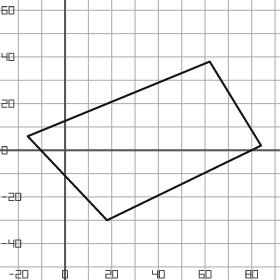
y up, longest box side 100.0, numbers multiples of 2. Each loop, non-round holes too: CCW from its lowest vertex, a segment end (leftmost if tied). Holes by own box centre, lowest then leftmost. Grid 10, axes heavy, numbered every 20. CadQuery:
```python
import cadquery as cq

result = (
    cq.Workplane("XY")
    .moveTo(18.0, -30.0)
    .lineTo(84.0, 2.0)
    .lineTo(62.0, 38.0)
    .lineTo(-16.0, 6.0)
    .close()
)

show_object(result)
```